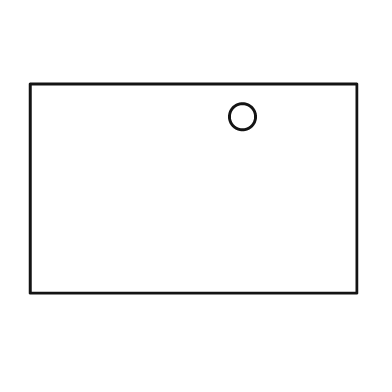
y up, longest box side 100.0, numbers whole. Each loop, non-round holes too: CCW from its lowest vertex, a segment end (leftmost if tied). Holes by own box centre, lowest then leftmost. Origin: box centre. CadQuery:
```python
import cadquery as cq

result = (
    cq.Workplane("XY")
    .moveTo(-50.0, -32.0)
    .lineTo(50.0, -32.0)
    .lineTo(50.0, 32.0)
    .lineTo(-50.0, 32.0)
    .close()
    .moveTo(15.0, 22.0)
    .circle(4.0)
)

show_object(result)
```